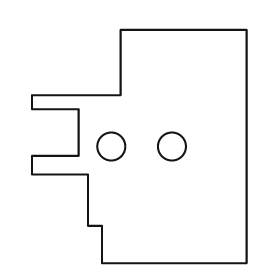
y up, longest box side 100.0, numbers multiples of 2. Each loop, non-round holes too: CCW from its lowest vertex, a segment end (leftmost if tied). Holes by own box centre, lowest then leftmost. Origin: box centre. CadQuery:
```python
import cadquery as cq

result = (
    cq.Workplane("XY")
    .moveTo(-16.0, -50.0)
    .lineTo(46.0, -50.0)
    .lineTo(46.0, 50.0)
    .lineTo(-8.0, 50.0)
    .lineTo(-8.0, 22.0)
    .lineTo(-46.0, 22.0)
    .lineTo(-46.0, 16.0)
    .lineTo(-26.0, 16.0)
    .lineTo(-26.0, -4.0)
    .lineTo(-46.0, -4.0)
    .lineTo(-46.0, -12.0)
    .lineTo(-22.0, -12.0)
    .lineTo(-22.0, -34.0)
    .lineTo(-16.0, -34.0)
    .close()
    .moveTo(-12.0, 0.0)
    .circle(6.0)
    .moveTo(14.0, 0.0)
    .circle(6.0)
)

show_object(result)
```